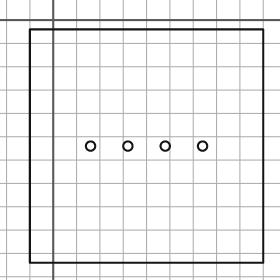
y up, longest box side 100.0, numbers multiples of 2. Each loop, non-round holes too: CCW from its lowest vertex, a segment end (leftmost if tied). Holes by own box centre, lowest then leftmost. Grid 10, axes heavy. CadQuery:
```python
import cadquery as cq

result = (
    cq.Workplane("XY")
    .moveTo(-10.0, -104.0)
    .lineTo(90.0, -104.0)
    .lineTo(90.0, -4.0)
    .lineTo(-10.0, -4.0)
    .close()
    .moveTo(16.0, -54.0)
    .circle(2.0)
    .moveTo(32.0, -54.0)
    .circle(2.0)
    .moveTo(48.0, -54.0)
    .circle(2.0)
    .moveTo(64.0, -54.0)
    .circle(2.0)
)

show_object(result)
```